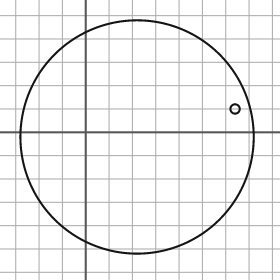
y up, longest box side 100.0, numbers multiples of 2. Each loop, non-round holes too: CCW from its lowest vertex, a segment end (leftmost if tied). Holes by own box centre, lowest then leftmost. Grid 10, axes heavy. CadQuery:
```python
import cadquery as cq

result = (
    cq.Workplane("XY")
    .moveTo(22.0, -2.0)
    .circle(50.0)
    .moveTo(64.0, 10.0)
    .circle(2.0)
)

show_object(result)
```